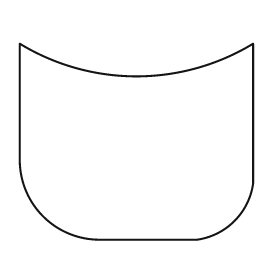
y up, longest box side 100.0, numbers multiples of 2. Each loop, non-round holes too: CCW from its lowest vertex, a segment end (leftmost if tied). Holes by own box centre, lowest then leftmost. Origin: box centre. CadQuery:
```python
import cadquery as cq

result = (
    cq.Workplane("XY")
    .moveTo(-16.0, -42.0)
    .lineTo(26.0, -42.0)
    .threePointArc((42.0, -34.0), (50.0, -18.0))
    .lineTo(50.0, 42.0)
    .threePointArc((0.0, 28.0), (-50.0, 42.0))
    .lineTo(-50.0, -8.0)
    .threePointArc((-40.0, -32.0), (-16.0, -42.0))
    .close()
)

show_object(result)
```